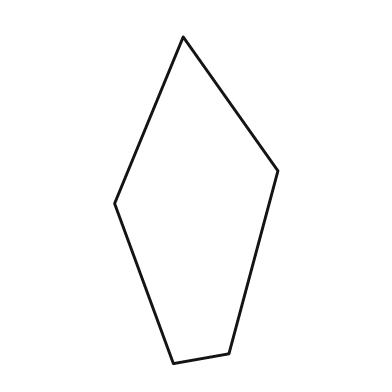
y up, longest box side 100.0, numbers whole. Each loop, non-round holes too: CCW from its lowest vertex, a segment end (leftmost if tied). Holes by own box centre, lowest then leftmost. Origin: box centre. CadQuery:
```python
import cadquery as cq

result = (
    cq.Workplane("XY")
    .moveTo(-7.0, -50.0)
    .lineTo(10.0, -47.0)
    .lineTo(25.0, 9.0)
    .lineTo(-4.0, 50.0)
    .lineTo(-25.0, -1.0)
    .close()
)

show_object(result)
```